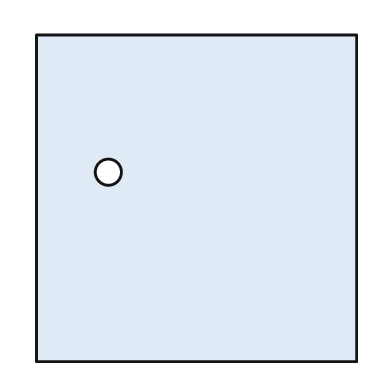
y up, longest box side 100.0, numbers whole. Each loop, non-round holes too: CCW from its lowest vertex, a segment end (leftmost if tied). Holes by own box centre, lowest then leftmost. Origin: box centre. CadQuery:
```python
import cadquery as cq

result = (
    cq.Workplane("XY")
    .moveTo(-49.0, -50.0)
    .lineTo(49.0, -50.0)
    .lineTo(49.0, 50.0)
    .lineTo(-49.0, 50.0)
    .close()
    .moveTo(-27.0, 8.0)
    .circle(4.0)
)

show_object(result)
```